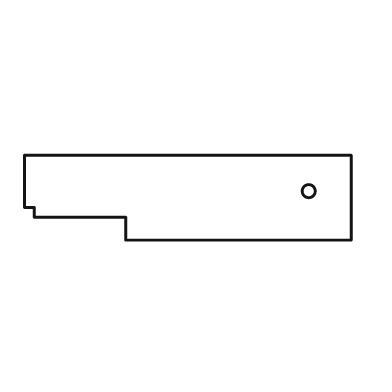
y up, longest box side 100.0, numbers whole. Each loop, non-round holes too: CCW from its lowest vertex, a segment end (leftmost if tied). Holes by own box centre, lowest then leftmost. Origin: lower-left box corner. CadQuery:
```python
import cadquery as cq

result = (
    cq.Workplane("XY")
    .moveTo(31.0, 0.0)
    .lineTo(100.0, 0.0)
    .lineTo(100.0, 26.0)
    .lineTo(0.0, 26.0)
    .lineTo(0.0, 10.0)
    .lineTo(3.0, 10.0)
    .lineTo(3.0, 7.0)
    .lineTo(31.0, 7.0)
    .close()
    .moveTo(87.0, 15.0)
    .circle(2.0)
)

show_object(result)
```